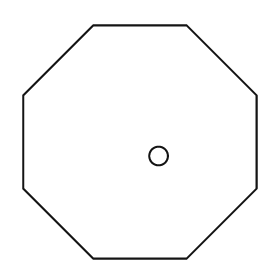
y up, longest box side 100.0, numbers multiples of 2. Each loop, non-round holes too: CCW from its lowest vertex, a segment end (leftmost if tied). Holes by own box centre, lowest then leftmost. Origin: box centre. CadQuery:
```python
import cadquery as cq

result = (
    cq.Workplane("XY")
    .moveTo(-20.0, -50.0)
    .lineTo(20.0, -50.0)
    .lineTo(50.0, -20.0)
    .lineTo(50.0, 20.0)
    .lineTo(20.0, 50.0)
    .lineTo(-20.0, 50.0)
    .lineTo(-50.0, 20.0)
    .lineTo(-50.0, -20.0)
    .close()
    .moveTo(8.0, -6.0)
    .circle(4.0)
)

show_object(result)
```